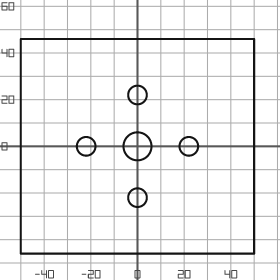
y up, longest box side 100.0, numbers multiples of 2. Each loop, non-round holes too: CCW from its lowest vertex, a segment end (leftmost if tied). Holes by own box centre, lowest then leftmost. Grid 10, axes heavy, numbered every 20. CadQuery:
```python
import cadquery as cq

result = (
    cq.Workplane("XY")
    .moveTo(-50.0, -46.0)
    .lineTo(50.0, -46.0)
    .lineTo(50.0, 46.0)
    .lineTo(-50.0, 46.0)
    .close()
    .moveTo(0.0, -22.0)
    .circle(4.0)
    .moveTo(-22.0, 0.0)
    .circle(4.0)
    .moveTo(0.0, 0.0)
    .circle(6.0)
    .moveTo(22.0, 0.0)
    .circle(4.0)
    .moveTo(0.0, 22.0)
    .circle(4.0)
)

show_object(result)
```